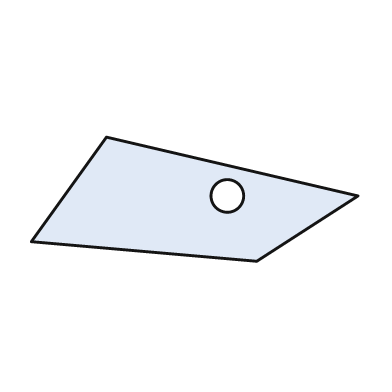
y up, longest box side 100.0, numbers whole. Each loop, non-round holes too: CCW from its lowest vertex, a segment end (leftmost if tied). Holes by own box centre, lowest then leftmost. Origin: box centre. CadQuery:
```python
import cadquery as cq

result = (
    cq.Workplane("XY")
    .moveTo(19.0, -19.0)
    .lineTo(50.0, 1.0)
    .lineTo(-27.0, 19.0)
    .lineTo(-50.0, -13.0)
    .close()
    .moveTo(10.0, 1.0)
    .circle(5.0)
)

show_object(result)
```